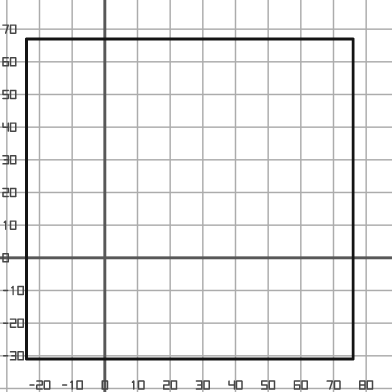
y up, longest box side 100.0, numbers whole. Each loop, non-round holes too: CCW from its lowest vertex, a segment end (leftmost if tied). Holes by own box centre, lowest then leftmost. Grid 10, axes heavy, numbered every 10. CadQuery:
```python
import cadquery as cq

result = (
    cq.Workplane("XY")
    .moveTo(-24.0, -31.0)
    .lineTo(76.0, -31.0)
    .lineTo(76.0, 67.0)
    .lineTo(-24.0, 67.0)
    .close()
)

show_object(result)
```